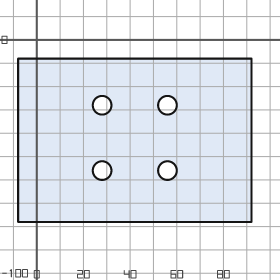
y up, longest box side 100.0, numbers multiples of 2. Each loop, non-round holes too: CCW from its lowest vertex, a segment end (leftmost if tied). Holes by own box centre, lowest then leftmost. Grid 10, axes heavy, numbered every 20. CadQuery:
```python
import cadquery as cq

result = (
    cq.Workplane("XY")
    .moveTo(-8.0, -78.0)
    .lineTo(92.0, -78.0)
    .lineTo(92.0, -8.0)
    .lineTo(-8.0, -8.0)
    .close()
    .moveTo(28.0, -56.0)
    .circle(4.0)
    .moveTo(56.0, -56.0)
    .circle(4.0)
    .moveTo(28.0, -28.0)
    .circle(4.0)
    .moveTo(56.0, -28.0)
    .circle(4.0)
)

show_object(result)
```